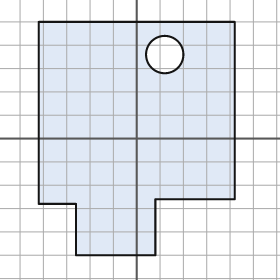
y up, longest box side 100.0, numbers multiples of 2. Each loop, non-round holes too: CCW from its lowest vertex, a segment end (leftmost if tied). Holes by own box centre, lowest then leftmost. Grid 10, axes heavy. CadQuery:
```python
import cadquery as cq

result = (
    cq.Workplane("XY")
    .moveTo(-26.0, -50.0)
    .lineTo(8.0, -50.0)
    .lineTo(8.0, -26.0)
    .lineTo(42.0, -26.0)
    .lineTo(42.0, 50.0)
    .lineTo(-42.0, 50.0)
    .lineTo(-42.0, -28.0)
    .lineTo(-26.0, -28.0)
    .close()
    .moveTo(12.0, 36.0)
    .circle(8.0)
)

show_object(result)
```